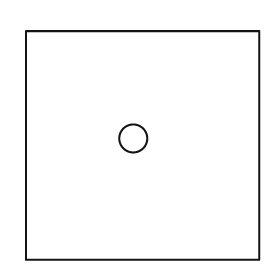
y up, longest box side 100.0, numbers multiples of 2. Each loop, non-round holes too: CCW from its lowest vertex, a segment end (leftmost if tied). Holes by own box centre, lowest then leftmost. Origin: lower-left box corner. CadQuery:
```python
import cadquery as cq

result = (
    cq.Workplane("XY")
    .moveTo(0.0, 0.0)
    .lineTo(100.0, 0.0)
    .lineTo(100.0, 98.0)
    .lineTo(0.0, 98.0)
    .close()
    .moveTo(46.0, 52.0)
    .circle(6.0)
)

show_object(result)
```